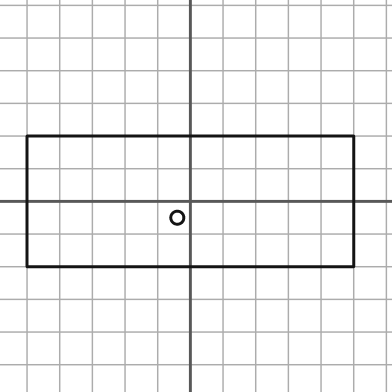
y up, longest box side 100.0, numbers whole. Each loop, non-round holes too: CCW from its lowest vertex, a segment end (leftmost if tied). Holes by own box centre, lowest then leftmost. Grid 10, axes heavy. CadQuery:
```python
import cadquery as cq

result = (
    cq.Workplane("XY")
    .moveTo(-50.0, -20.0)
    .lineTo(50.0, -20.0)
    .lineTo(50.0, 20.0)
    .lineTo(-50.0, 20.0)
    .close()
    .moveTo(-4.0, -5.0)
    .circle(2.0)
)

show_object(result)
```